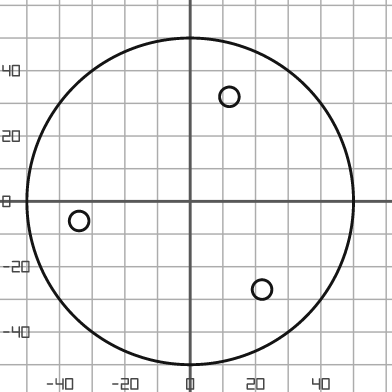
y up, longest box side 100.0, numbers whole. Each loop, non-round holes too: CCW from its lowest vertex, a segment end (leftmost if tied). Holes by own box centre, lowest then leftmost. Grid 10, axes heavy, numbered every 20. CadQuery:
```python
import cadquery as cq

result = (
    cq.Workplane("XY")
    .moveTo(0.0, 0.0)
    .circle(50.0)
    .moveTo(22.0, -27.0)
    .circle(3.0)
    .moveTo(-34.0, -6.0)
    .circle(3.0)
    .moveTo(12.0, 32.0)
    .circle(3.0)
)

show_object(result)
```